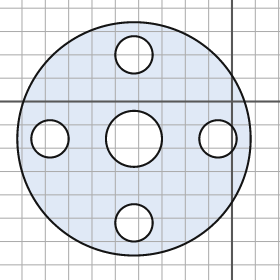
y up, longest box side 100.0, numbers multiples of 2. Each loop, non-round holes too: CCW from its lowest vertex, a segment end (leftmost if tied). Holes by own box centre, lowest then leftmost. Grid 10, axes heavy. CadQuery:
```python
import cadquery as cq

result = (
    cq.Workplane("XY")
    .moveTo(-42.0, -16.0)
    .circle(50.0)
    .moveTo(-42.0, -52.0)
    .circle(8.0)
    .moveTo(-78.0, -16.0)
    .circle(8.0)
    .moveTo(-42.0, -16.0)
    .circle(12.0)
    .moveTo(-6.0, -16.0)
    .circle(8.0)
    .moveTo(-42.0, 20.0)
    .circle(8.0)
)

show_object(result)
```